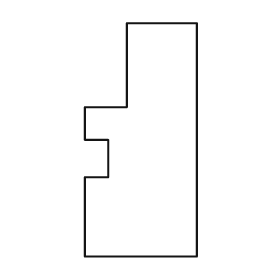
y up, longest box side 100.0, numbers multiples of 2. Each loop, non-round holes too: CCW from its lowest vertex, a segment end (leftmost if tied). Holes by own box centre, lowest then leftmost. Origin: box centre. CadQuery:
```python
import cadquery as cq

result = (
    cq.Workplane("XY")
    .moveTo(-24.0, -50.0)
    .lineTo(24.0, -50.0)
    .lineTo(24.0, 50.0)
    .lineTo(-6.0, 50.0)
    .lineTo(-6.0, 14.0)
    .lineTo(-24.0, 14.0)
    .lineTo(-24.0, 0.0)
    .lineTo(-14.0, 0.0)
    .lineTo(-14.0, -16.0)
    .lineTo(-24.0, -16.0)
    .close()
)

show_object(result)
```